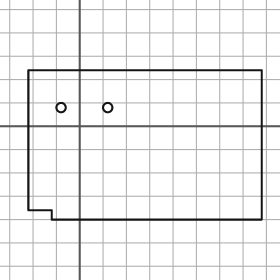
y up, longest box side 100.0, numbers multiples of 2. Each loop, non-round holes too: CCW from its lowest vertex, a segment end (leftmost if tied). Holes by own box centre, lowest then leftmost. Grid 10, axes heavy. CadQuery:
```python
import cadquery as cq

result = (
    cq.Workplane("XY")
    .moveTo(-12.0, -40.0)
    .lineTo(78.0, -40.0)
    .lineTo(78.0, 24.0)
    .lineTo(-22.0, 24.0)
    .lineTo(-22.0, -36.0)
    .lineTo(-12.0, -36.0)
    .close()
    .moveTo(-8.0, 8.0)
    .circle(2.0)
    .moveTo(12.0, 8.0)
    .circle(2.0)
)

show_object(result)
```